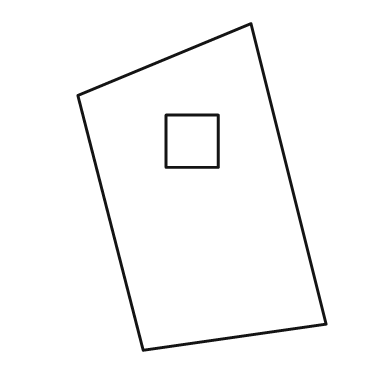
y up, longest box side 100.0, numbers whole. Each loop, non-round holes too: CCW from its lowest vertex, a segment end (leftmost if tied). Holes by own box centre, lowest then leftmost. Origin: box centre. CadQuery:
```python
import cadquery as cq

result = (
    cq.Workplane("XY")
    .moveTo(-18.0, -50.0)
    .lineTo(38.0, -42.0)
    .lineTo(15.0, 50.0)
    .lineTo(-38.0, 28.0)
    .close()
    .moveTo(-11.0, 6.0)
    .lineTo(5.0, 6.0)
    .lineTo(5.0, 22.0)
    .lineTo(-11.0, 22.0)
    .close()
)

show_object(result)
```